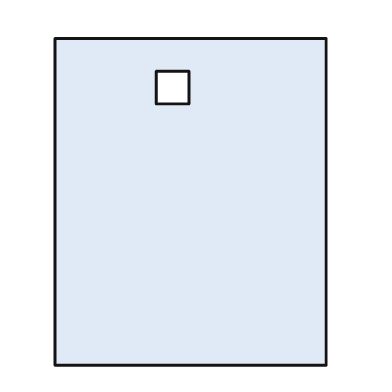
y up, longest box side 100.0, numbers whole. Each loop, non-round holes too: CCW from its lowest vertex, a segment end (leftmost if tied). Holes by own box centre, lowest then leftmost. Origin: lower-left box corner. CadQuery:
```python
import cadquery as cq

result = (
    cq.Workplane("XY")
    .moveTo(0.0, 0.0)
    .lineTo(83.0, 0.0)
    .lineTo(83.0, 100.0)
    .lineTo(0.0, 100.0)
    .close()
    .moveTo(31.0, 80.0)
    .lineTo(41.0, 80.0)
    .lineTo(41.0, 90.0)
    .lineTo(31.0, 90.0)
    .close()
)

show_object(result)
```